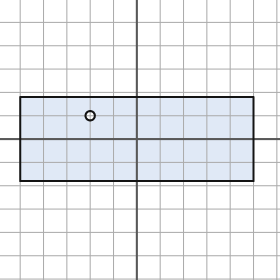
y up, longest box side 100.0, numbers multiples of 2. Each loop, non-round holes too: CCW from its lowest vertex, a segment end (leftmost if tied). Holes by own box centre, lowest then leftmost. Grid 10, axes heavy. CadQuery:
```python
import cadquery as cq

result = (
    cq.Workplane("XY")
    .moveTo(-50.0, -18.0)
    .lineTo(50.0, -18.0)
    .lineTo(50.0, 18.0)
    .lineTo(-50.0, 18.0)
    .close()
    .moveTo(-20.0, 10.0)
    .circle(2.0)
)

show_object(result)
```